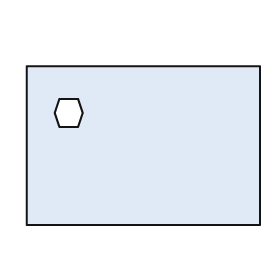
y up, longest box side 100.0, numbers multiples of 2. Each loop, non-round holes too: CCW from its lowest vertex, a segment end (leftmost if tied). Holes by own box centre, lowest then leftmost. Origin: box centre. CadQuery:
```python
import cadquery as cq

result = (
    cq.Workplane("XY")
    .moveTo(-50.0, -34.0)
    .lineTo(50.0, -34.0)
    .lineTo(50.0, 34.0)
    .lineTo(-50.0, 34.0)
    .close()
    .moveTo(-36.0, 8.0)
    .lineTo(-28.0, 8.0)
    .lineTo(-26.0, 14.0)
    .lineTo(-28.0, 20.0)
    .lineTo(-36.0, 20.0)
    .lineTo(-38.0, 14.0)
    .close()
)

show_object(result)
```